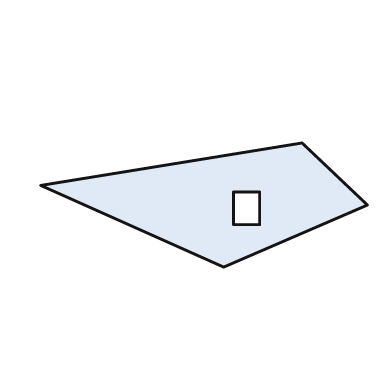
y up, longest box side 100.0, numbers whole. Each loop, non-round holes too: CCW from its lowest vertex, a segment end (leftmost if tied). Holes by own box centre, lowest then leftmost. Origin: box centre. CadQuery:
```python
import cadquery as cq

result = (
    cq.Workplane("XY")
    .moveTo(6.0, -19.0)
    .lineTo(50.0, 0.0)
    .lineTo(30.0, 19.0)
    .lineTo(-50.0, 6.0)
    .close()
    .moveTo(9.0, -6.0)
    .lineTo(17.0, -6.0)
    .lineTo(17.0, 4.0)
    .lineTo(9.0, 4.0)
    .close()
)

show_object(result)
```